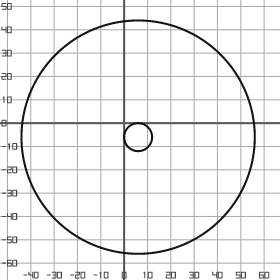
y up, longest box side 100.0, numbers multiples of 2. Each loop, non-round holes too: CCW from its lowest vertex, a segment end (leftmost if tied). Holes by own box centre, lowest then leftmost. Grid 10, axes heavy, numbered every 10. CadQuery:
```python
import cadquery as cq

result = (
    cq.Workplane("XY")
    .moveTo(6.0, -6.0)
    .circle(50.0)
    .moveTo(6.0, -6.0)
    .circle(6.0)
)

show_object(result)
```